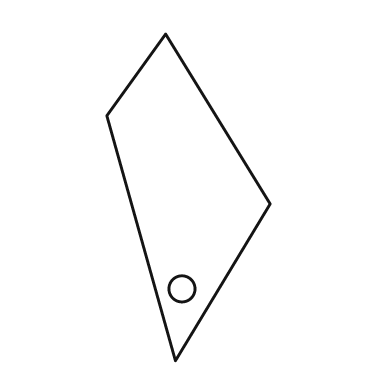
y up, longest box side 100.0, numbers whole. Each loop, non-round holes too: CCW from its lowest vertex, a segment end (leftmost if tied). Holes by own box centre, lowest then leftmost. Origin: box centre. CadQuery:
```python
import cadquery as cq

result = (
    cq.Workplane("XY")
    .moveTo(-4.0, -50.0)
    .lineTo(25.0, -2.0)
    .lineTo(-7.0, 50.0)
    .lineTo(-25.0, 25.0)
    .close()
    .moveTo(-2.0, -28.0)
    .circle(4.0)
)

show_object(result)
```